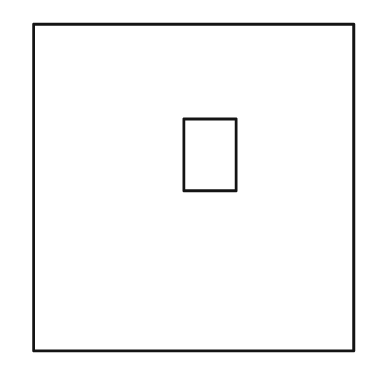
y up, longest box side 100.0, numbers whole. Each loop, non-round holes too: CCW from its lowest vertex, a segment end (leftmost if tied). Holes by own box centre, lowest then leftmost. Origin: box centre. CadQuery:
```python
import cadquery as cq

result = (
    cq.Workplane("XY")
    .moveTo(-49.0, -50.0)
    .lineTo(49.0, -50.0)
    .lineTo(49.0, 50.0)
    .lineTo(-49.0, 50.0)
    .close()
    .moveTo(-3.0, -1.0)
    .lineTo(13.0, -1.0)
    .lineTo(13.0, 21.0)
    .lineTo(-3.0, 21.0)
    .close()
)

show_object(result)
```